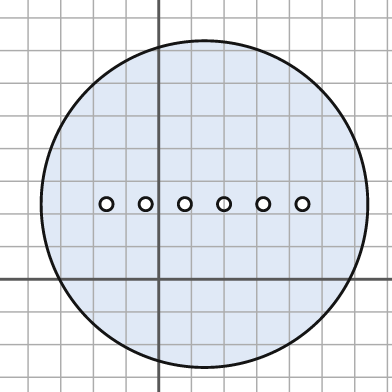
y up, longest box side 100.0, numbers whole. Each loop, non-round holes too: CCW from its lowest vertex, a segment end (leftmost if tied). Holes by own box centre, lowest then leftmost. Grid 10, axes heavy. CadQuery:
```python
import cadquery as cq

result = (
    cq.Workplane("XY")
    .moveTo(14.0, 23.0)
    .circle(50.0)
    .moveTo(-16.0, 23.0)
    .circle(2.0)
    .moveTo(-4.0, 23.0)
    .circle(2.0)
    .moveTo(8.0, 23.0)
    .circle(2.0)
    .moveTo(20.0, 23.0)
    .circle(2.0)
    .moveTo(32.0, 23.0)
    .circle(2.0)
    .moveTo(44.0, 23.0)
    .circle(2.0)
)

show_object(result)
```